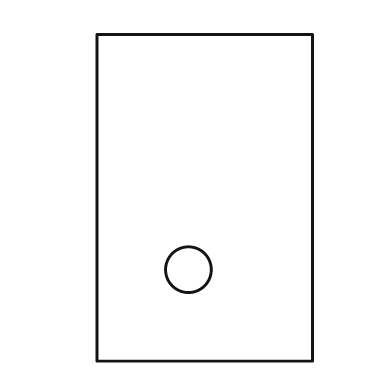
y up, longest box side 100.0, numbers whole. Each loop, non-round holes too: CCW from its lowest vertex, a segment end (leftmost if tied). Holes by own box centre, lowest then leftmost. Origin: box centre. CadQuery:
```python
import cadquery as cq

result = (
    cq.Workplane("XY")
    .moveTo(-33.0, -50.0)
    .lineTo(33.0, -50.0)
    .lineTo(33.0, 50.0)
    .lineTo(-33.0, 50.0)
    .close()
    .moveTo(-5.0, -22.0)
    .circle(7.0)
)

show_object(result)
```